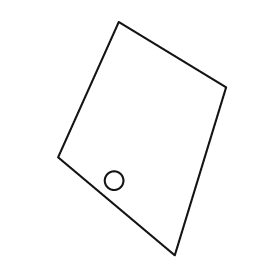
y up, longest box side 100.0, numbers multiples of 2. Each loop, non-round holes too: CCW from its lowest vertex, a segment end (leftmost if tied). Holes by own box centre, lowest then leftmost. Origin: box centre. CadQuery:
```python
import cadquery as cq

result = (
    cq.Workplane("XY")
    .moveTo(14.0, -50.0)
    .lineTo(36.0, 22.0)
    .lineTo(-10.0, 50.0)
    .lineTo(-36.0, -8.0)
    .close()
    .moveTo(-12.0, -18.0)
    .circle(4.0)
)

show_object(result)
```